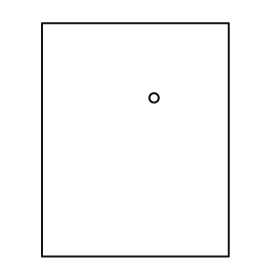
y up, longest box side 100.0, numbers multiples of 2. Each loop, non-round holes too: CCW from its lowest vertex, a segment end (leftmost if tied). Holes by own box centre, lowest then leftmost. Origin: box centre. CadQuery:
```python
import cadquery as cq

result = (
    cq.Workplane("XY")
    .moveTo(-40.0, -50.0)
    .lineTo(40.0, -50.0)
    .lineTo(40.0, 50.0)
    .lineTo(-40.0, 50.0)
    .close()
    .moveTo(8.0, 18.0)
    .circle(2.0)
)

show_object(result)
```